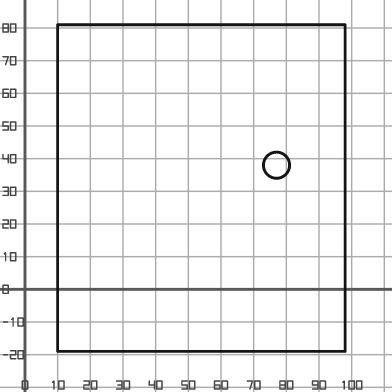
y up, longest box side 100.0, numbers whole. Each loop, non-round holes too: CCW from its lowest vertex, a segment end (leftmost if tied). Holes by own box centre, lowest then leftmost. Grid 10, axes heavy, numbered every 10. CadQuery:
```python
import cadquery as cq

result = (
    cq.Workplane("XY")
    .moveTo(10.0, -19.0)
    .lineTo(98.0, -19.0)
    .lineTo(98.0, 81.0)
    .lineTo(10.0, 81.0)
    .close()
    .moveTo(77.0, 38.0)
    .circle(4.0)
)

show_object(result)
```